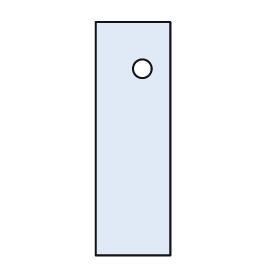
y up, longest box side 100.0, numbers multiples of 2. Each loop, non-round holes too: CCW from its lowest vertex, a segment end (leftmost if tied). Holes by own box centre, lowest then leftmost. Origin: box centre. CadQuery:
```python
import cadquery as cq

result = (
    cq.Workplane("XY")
    .moveTo(-16.0, -50.0)
    .lineTo(16.0, -50.0)
    .lineTo(16.0, 50.0)
    .lineTo(-16.0, 50.0)
    .close()
    .moveTo(4.0, 30.0)
    .circle(4.0)
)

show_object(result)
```